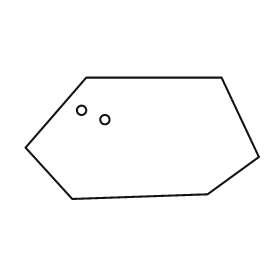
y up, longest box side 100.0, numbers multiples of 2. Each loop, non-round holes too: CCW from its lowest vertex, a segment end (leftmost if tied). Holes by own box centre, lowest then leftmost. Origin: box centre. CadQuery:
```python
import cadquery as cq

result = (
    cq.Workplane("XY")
    .moveTo(-30.0, -26.0)
    .lineTo(28.0, -24.0)
    .lineTo(50.0, -8.0)
    .lineTo(34.0, 26.0)
    .lineTo(-24.0, 26.0)
    .lineTo(-50.0, -4.0)
    .close()
    .moveTo(-16.0, 8.0)
    .circle(2.0)
    .moveTo(-26.0, 12.0)
    .circle(2.0)
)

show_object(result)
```